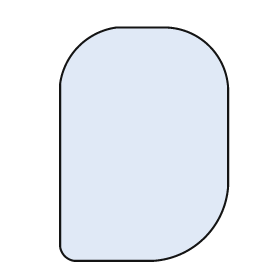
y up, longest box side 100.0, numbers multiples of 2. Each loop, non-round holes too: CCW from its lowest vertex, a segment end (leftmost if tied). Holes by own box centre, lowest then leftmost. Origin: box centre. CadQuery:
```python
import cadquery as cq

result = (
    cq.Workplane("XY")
    .moveTo(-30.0, -50.0)
    .lineTo(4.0, -50.0)
    .threePointArc((26.0, -40.0), (36.0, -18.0))
    .lineTo(36.0, 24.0)
    .threePointArc((28.0, 42.0), (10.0, 50.0))
    .lineTo(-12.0, 50.0)
    .threePointArc((-28.0, 42.0), (-36.0, 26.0))
    .lineTo(-36.0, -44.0)
    .threePointArc((-34.0, -48.0), (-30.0, -50.0))
    .close()
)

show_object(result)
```